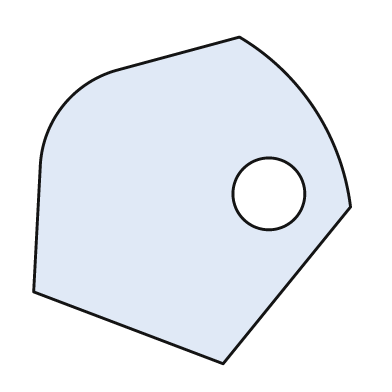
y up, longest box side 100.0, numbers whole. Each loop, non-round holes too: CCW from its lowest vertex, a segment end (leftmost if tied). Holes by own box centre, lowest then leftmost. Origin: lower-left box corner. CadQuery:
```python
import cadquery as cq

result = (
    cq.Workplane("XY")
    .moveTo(58.0, 0.0)
    .lineTo(97.0, 48.0)
    .threePointArc((86.0, 78.0), (63.0, 100.0))
    .lineTo(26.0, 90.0)
    .threePointArc((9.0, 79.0), (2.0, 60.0))
    .lineTo(0.0, 22.0)
    .close()
    .moveTo(72.0, 52.0)
    .circle(11.0)
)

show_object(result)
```